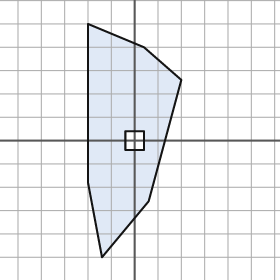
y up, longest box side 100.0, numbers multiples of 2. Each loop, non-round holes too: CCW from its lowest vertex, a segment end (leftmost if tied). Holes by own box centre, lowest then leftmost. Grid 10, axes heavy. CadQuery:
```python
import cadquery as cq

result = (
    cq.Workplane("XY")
    .moveTo(-14.0, -50.0)
    .lineTo(6.0, -26.0)
    .lineTo(20.0, 26.0)
    .lineTo(4.0, 40.0)
    .lineTo(-20.0, 50.0)
    .lineTo(-20.0, -18.0)
    .close()
    .moveTo(-4.0, -4.0)
    .lineTo(4.0, -4.0)
    .lineTo(4.0, 4.0)
    .lineTo(-4.0, 4.0)
    .close()
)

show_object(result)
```